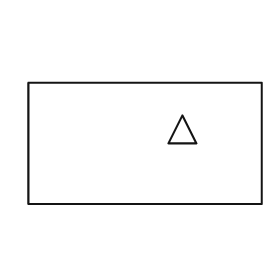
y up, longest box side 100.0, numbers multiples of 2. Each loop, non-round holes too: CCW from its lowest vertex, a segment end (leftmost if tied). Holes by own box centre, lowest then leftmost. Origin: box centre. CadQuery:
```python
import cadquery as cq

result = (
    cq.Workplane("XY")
    .moveTo(-50.0, -26.0)
    .lineTo(50.0, -26.0)
    .lineTo(50.0, 26.0)
    .lineTo(-50.0, 26.0)
    .close()
    .moveTo(10.0, 0.0)
    .lineTo(22.0, 0.0)
    .lineTo(16.0, 12.0)
    .close()
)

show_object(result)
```